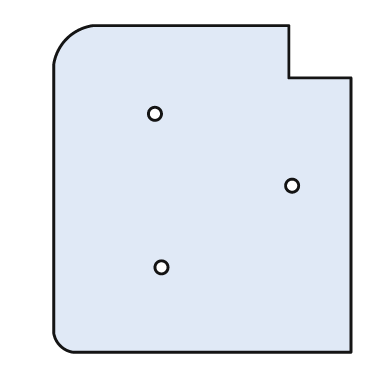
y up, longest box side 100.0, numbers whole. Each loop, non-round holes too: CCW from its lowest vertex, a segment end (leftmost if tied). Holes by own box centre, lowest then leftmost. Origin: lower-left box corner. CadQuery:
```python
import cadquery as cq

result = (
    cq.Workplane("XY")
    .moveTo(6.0, 0.0)
    .lineTo(91.0, 0.0)
    .lineTo(91.0, 84.0)
    .lineTo(72.0, 84.0)
    .lineTo(72.0, 100.0)
    .lineTo(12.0, 100.0)
    .threePointArc((4.0, 96.0), (0.0, 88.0))
    .lineTo(0.0, 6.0)
    .threePointArc((2.0, 2.0), (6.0, 0.0))
    .close()
    .moveTo(33.0, 26.0)
    .circle(2.0)
    .moveTo(73.0, 51.0)
    .circle(2.0)
    .moveTo(31.0, 73.0)
    .circle(2.0)
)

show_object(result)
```